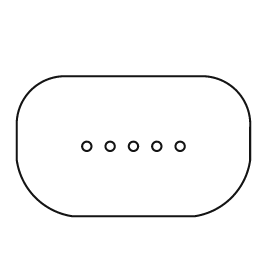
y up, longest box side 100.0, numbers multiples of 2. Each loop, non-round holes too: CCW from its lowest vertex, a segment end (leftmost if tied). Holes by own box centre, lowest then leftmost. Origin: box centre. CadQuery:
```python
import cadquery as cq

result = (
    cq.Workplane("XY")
    .moveTo(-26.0, -30.0)
    .lineTo(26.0, -30.0)
    .threePointArc((42.0, -22.0), (50.0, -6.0))
    .lineTo(50.0, 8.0)
    .threePointArc((44.0, 24.0), (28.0, 30.0))
    .lineTo(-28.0, 30.0)
    .threePointArc((-44.0, 24.0), (-50.0, 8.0))
    .lineTo(-50.0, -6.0)
    .threePointArc((-42.0, -22.0), (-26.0, -30.0))
    .close()
    .moveTo(-20.0, 0.0)
    .circle(2.0)
    .moveTo(-10.0, 0.0)
    .circle(2.0)
    .moveTo(0.0, 0.0)
    .circle(2.0)
    .moveTo(10.0, 0.0)
    .circle(2.0)
    .moveTo(20.0, 0.0)
    .circle(2.0)
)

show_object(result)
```